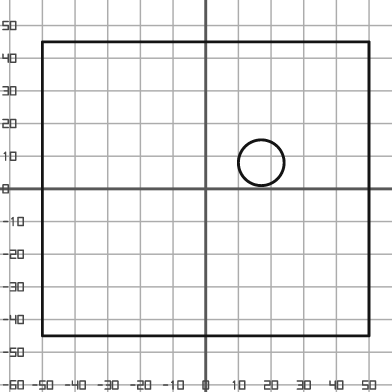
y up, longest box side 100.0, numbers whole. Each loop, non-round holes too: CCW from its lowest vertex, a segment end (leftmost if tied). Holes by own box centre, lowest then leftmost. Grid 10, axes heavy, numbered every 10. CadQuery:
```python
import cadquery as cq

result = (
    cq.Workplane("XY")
    .moveTo(-50.0, -45.0)
    .lineTo(50.0, -45.0)
    .lineTo(50.0, 45.0)
    .lineTo(-50.0, 45.0)
    .close()
    .moveTo(17.0, 8.0)
    .circle(7.0)
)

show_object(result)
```